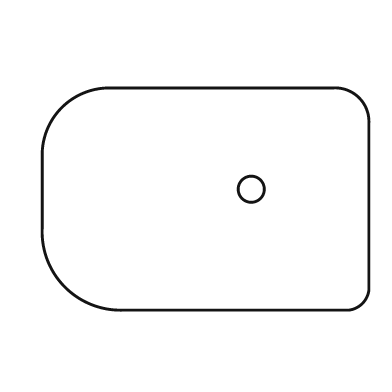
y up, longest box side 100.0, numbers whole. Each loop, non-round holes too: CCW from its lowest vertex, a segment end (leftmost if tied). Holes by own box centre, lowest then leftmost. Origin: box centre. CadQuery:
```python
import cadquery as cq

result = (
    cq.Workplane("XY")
    .moveTo(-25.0, -34.0)
    .lineTo(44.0, -34.0)
    .threePointArc((48.0, -32.0), (50.0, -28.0))
    .lineTo(50.0, 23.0)
    .threePointArc((47.0, 31.0), (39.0, 34.0))
    .lineTo(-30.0, 34.0)
    .threePointArc((-44.0, 28.0), (-50.0, 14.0))
    .lineTo(-50.0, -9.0)
    .threePointArc((-43.0, -27.0), (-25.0, -34.0))
    .close()
    .moveTo(14.0, 3.0)
    .circle(4.0)
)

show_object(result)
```